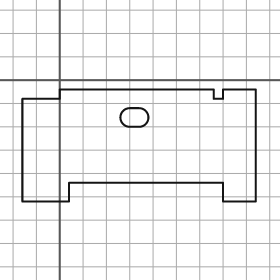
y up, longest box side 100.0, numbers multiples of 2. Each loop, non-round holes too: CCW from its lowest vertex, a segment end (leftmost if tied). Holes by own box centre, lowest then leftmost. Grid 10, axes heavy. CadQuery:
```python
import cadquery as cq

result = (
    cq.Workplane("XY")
    .moveTo(-16.0, -52.0)
    .lineTo(4.0, -52.0)
    .lineTo(4.0, -44.0)
    .lineTo(70.0, -44.0)
    .lineTo(70.0, -52.0)
    .lineTo(84.0, -52.0)
    .lineTo(84.0, -4.0)
    .lineTo(70.0, -4.0)
    .lineTo(70.0, -8.0)
    .lineTo(66.0, -8.0)
    .lineTo(66.0, -4.0)
    .lineTo(0.0, -4.0)
    .lineTo(0.0, -8.0)
    .lineTo(-16.0, -8.0)
    .close()
    .moveTo(30.0, -20.0)
    .lineTo(34.0, -20.0)
    .threePointArc((38.0, -16.0), (34.0, -12.0))
    .lineTo(30.0, -12.0)
    .threePointArc((26.0, -16.0), (30.0, -20.0))
    .close()
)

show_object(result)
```